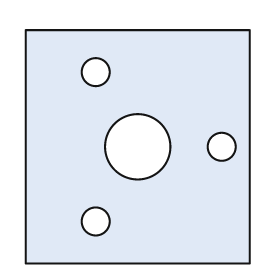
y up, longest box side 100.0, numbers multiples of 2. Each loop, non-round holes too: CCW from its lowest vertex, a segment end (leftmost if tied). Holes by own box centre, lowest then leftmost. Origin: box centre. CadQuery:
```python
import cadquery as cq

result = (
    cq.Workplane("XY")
    .moveTo(-48.0, -50.0)
    .lineTo(48.0, -50.0)
    .lineTo(48.0, 50.0)
    .lineTo(-48.0, 50.0)
    .close()
    .moveTo(-18.0, -32.0)
    .circle(6.0)
    .moveTo(0.0, 0.0)
    .circle(14.0)
    .moveTo(36.0, 0.0)
    .circle(6.0)
    .moveTo(-18.0, 32.0)
    .circle(6.0)
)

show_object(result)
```